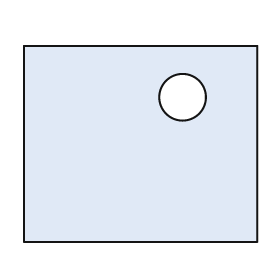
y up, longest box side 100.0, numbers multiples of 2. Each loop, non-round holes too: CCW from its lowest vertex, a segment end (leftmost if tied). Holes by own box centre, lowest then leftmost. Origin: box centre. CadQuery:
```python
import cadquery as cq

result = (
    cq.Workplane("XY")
    .moveTo(-50.0, -42.0)
    .lineTo(50.0, -42.0)
    .lineTo(50.0, 42.0)
    .lineTo(-50.0, 42.0)
    .close()
    .moveTo(18.0, 20.0)
    .circle(10.0)
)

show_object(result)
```